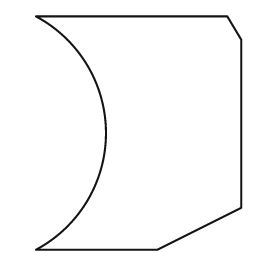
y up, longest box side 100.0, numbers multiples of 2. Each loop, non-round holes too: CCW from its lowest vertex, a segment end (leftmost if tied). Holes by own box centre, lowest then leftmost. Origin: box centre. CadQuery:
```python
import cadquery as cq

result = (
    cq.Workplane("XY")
    .moveTo(-44.0, -50.0)
    .lineTo(8.0, -50.0)
    .lineTo(44.0, -32.0)
    .lineTo(44.0, 40.0)
    .lineTo(38.0, 50.0)
    .lineTo(-44.0, 50.0)
    .threePointArc((-14.0, 0.0), (-44.0, -50.0))
    .close()
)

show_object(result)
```